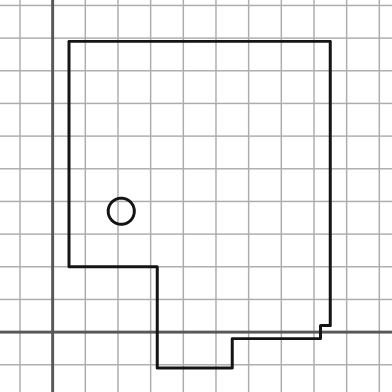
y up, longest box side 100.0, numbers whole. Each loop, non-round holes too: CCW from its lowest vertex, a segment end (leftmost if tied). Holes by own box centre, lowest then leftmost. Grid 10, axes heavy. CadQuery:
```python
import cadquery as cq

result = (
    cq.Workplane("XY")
    .moveTo(32.0, -11.0)
    .lineTo(55.0, -11.0)
    .lineTo(55.0, -2.0)
    .lineTo(82.0, -2.0)
    .lineTo(82.0, 2.0)
    .lineTo(85.0, 2.0)
    .lineTo(85.0, 89.0)
    .lineTo(5.0, 89.0)
    .lineTo(5.0, 20.0)
    .lineTo(32.0, 20.0)
    .close()
    .moveTo(21.0, 37.0)
    .circle(4.0)
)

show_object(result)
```